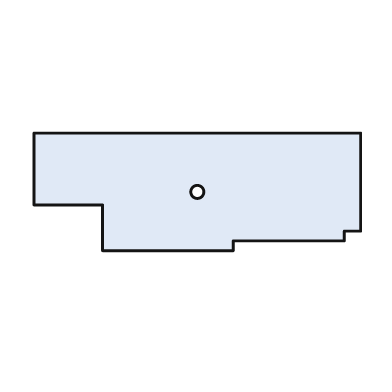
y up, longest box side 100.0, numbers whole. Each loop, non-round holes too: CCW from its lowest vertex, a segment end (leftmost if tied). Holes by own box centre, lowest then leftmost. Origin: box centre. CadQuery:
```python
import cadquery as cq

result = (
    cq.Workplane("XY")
    .moveTo(-29.0, -18.0)
    .lineTo(11.0, -18.0)
    .lineTo(11.0, -15.0)
    .lineTo(45.0, -15.0)
    .lineTo(45.0, -12.0)
    .lineTo(50.0, -12.0)
    .lineTo(50.0, 18.0)
    .lineTo(-50.0, 18.0)
    .lineTo(-50.0, -4.0)
    .lineTo(-29.0, -4.0)
    .close()
    .moveTo(0.0, 0.0)
    .circle(2.0)
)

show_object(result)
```